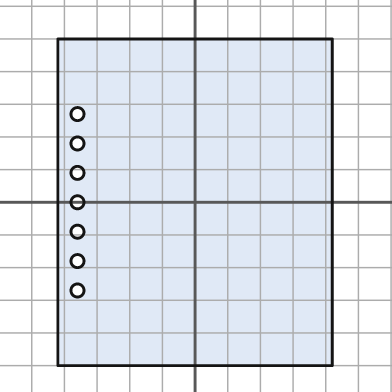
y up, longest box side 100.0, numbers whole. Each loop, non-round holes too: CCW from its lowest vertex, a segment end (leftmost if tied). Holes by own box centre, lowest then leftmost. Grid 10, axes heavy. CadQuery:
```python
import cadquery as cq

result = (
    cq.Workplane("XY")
    .moveTo(-42.0, -50.0)
    .lineTo(42.0, -50.0)
    .lineTo(42.0, 50.0)
    .lineTo(-42.0, 50.0)
    .close()
    .moveTo(-36.0, -27.0)
    .circle(2.0)
    .moveTo(-36.0, -18.0)
    .circle(2.0)
    .moveTo(-36.0, -9.0)
    .circle(2.0)
    .moveTo(-36.0, 0.0)
    .circle(2.0)
    .moveTo(-36.0, 9.0)
    .circle(2.0)
    .moveTo(-36.0, 18.0)
    .circle(2.0)
    .moveTo(-36.0, 27.0)
    .circle(2.0)
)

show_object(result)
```